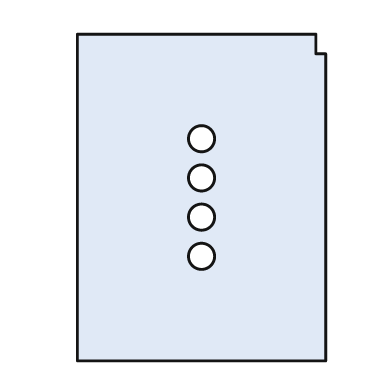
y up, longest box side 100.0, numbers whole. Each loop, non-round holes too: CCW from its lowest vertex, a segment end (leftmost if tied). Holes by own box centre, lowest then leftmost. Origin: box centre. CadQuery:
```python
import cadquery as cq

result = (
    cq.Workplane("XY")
    .moveTo(-38.0, -50.0)
    .lineTo(38.0, -50.0)
    .lineTo(38.0, 44.0)
    .lineTo(35.0, 44.0)
    .lineTo(35.0, 50.0)
    .lineTo(-38.0, 50.0)
    .close()
    .moveTo(0.0, -18.0)
    .circle(4.0)
    .moveTo(0.0, -6.0)
    .circle(4.0)
    .moveTo(0.0, 6.0)
    .circle(4.0)
    .moveTo(0.0, 18.0)
    .circle(4.0)
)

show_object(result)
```